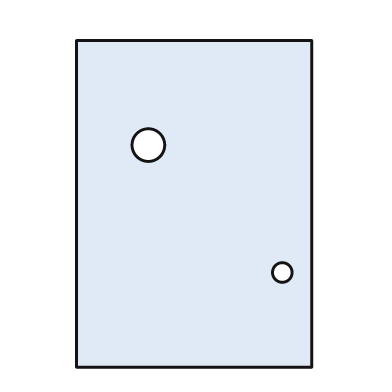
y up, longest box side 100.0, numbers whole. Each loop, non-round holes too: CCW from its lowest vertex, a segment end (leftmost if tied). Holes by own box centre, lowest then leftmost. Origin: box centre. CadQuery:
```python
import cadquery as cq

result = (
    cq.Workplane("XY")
    .moveTo(-36.0, -50.0)
    .lineTo(36.0, -50.0)
    .lineTo(36.0, 50.0)
    .lineTo(-36.0, 50.0)
    .close()
    .moveTo(27.0, -21.0)
    .circle(3.0)
    .moveTo(-14.0, 18.0)
    .circle(5.0)
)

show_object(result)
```